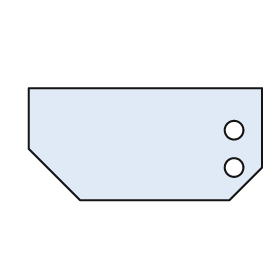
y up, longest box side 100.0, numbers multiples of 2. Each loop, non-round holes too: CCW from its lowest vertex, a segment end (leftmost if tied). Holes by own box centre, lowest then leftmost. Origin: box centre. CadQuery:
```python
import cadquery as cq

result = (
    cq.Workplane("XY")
    .moveTo(-28.0, -24.0)
    .lineTo(36.0, -24.0)
    .lineTo(50.0, -10.0)
    .lineTo(50.0, 24.0)
    .lineTo(-50.0, 24.0)
    .lineTo(-50.0, -2.0)
    .close()
    .moveTo(38.0, -10.0)
    .circle(4.0)
    .moveTo(38.0, 6.0)
    .circle(4.0)
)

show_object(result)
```